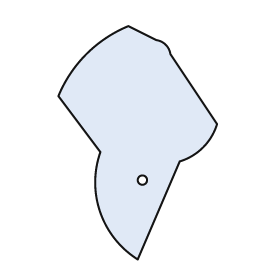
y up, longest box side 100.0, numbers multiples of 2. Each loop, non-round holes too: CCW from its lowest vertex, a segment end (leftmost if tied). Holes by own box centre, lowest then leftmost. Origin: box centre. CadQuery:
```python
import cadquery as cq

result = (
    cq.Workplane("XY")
    .moveTo(0.0, -50.0)
    .lineTo(18.0, -8.0)
    .threePointArc((28.0, -2.0), (34.0, 8.0))
    .lineTo(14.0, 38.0)
    .threePointArc((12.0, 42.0), (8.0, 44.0))
    .lineTo(-4.0, 50.0)
    .threePointArc((-22.0, 38.0), (-34.0, 20.0))
    .lineTo(-16.0, -4.0)
    .threePointArc((-16.0, -30.0), (0.0, -50.0))
    .close()
    .moveTo(2.0, -16.0)
    .circle(2.0)
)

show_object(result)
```